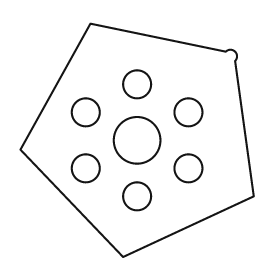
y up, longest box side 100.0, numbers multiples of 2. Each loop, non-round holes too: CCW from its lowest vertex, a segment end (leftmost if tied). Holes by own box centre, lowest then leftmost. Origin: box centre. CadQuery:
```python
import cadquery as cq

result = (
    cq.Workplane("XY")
    .moveTo(-6.0, -50.0)
    .lineTo(50.0, -24.0)
    .lineTo(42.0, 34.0)
    .threePointArc((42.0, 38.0), (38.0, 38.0))
    .lineTo(-20.0, 50.0)
    .lineTo(-50.0, -4.0)
    .close()
    .moveTo(0.0, -24.0)
    .circle(6.0)
    .moveTo(-22.0, -12.0)
    .circle(6.0)
    .moveTo(22.0, -12.0)
    .circle(6.0)
    .moveTo(0.0, 0.0)
    .circle(10.0)
    .moveTo(-22.0, 12.0)
    .circle(6.0)
    .moveTo(22.0, 12.0)
    .circle(6.0)
    .moveTo(0.0, 24.0)
    .circle(6.0)
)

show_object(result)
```